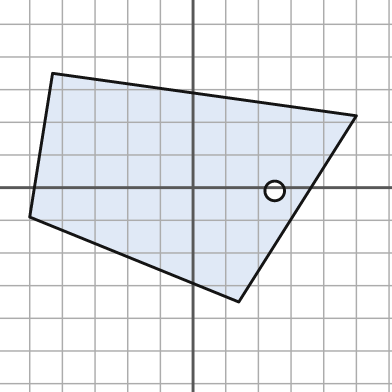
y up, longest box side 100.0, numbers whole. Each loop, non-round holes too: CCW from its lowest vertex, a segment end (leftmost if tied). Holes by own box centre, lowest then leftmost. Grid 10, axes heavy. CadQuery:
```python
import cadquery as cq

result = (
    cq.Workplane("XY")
    .moveTo(14.0, -35.0)
    .lineTo(50.0, 22.0)
    .lineTo(-43.0, 35.0)
    .lineTo(-50.0, -9.0)
    .close()
    .moveTo(25.0, -1.0)
    .circle(3.0)
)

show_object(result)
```